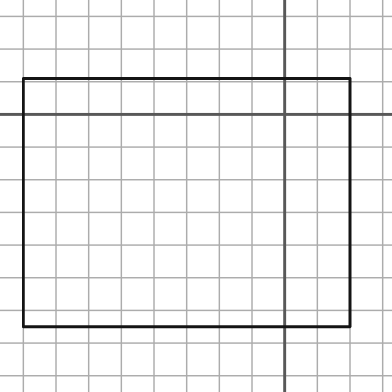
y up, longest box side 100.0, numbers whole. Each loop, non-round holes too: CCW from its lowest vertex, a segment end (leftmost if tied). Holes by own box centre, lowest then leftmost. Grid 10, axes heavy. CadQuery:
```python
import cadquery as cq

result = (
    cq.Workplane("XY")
    .moveTo(-80.0, -65.0)
    .lineTo(20.0, -65.0)
    .lineTo(20.0, 11.0)
    .lineTo(-80.0, 11.0)
    .close()
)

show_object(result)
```